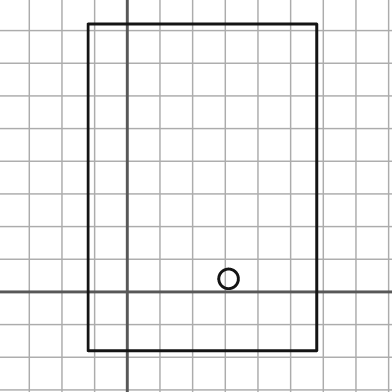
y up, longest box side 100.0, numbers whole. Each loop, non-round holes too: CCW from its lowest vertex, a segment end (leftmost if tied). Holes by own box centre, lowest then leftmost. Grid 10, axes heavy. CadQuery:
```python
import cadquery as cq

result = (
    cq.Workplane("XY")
    .moveTo(-12.0, -18.0)
    .lineTo(58.0, -18.0)
    .lineTo(58.0, 82.0)
    .lineTo(-12.0, 82.0)
    .close()
    .moveTo(31.0, 4.0)
    .circle(3.0)
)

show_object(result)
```